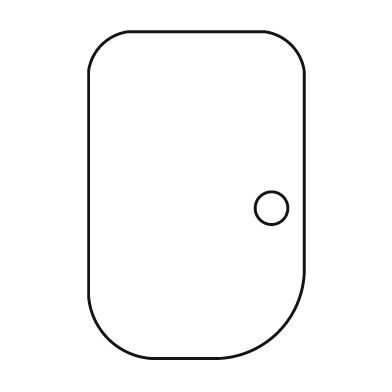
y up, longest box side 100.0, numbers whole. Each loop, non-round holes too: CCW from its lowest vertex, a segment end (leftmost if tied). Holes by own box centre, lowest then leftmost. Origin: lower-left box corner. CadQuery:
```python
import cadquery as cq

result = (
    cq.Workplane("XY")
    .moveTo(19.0, 0.0)
    .lineTo(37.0, 0.0)
    .threePointArc((58.0, 8.0), (66.0, 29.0))
    .lineTo(66.0, 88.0)
    .threePointArc((62.0, 96.0), (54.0, 100.0))
    .lineTo(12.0, 100.0)
    .threePointArc((4.0, 96.0), (0.0, 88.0))
    .lineTo(0.0, 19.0)
    .threePointArc((6.0, 6.0), (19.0, 0.0))
    .close()
    .moveTo(56.0, 46.0)
    .circle(5.0)
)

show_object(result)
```